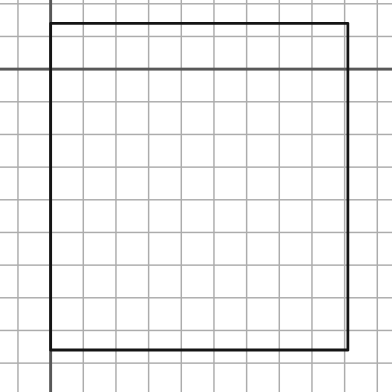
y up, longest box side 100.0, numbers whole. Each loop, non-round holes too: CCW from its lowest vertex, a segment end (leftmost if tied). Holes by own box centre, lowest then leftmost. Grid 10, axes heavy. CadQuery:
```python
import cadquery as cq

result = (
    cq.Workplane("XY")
    .moveTo(0.0, -86.0)
    .lineTo(91.0, -86.0)
    .lineTo(91.0, 14.0)
    .lineTo(0.0, 14.0)
    .close()
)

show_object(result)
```